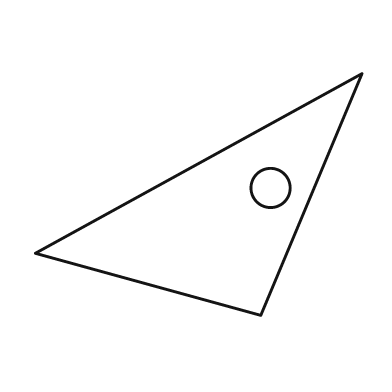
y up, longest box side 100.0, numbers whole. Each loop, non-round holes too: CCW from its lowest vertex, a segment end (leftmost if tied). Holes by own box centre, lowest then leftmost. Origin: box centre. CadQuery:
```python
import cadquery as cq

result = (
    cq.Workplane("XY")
    .moveTo(19.0, -37.0)
    .lineTo(50.0, 37.0)
    .lineTo(-50.0, -18.0)
    .close()
    .moveTo(22.0, 2.0)
    .circle(6.0)
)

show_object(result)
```